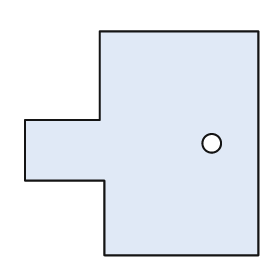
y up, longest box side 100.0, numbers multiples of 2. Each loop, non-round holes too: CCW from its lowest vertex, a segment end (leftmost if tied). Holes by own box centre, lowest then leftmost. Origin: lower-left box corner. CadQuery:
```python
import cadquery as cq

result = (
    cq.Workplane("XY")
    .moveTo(34.0, 0.0)
    .lineTo(100.0, 0.0)
    .lineTo(100.0, 96.0)
    .lineTo(32.0, 96.0)
    .lineTo(32.0, 58.0)
    .lineTo(0.0, 58.0)
    .lineTo(0.0, 32.0)
    .lineTo(34.0, 32.0)
    .close()
    .moveTo(80.0, 48.0)
    .circle(4.0)
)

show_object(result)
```